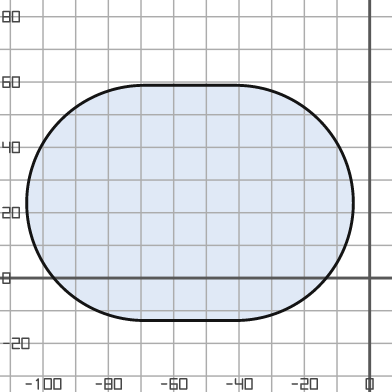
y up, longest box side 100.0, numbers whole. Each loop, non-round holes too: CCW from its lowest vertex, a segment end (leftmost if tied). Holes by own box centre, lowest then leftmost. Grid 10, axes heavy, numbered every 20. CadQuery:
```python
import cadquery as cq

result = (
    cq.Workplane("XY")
    .moveTo(-69.0, -13.0)
    .lineTo(-41.0, -13.0)
    .threePointArc((-5.0, 23.0), (-41.0, 59.0))
    .lineTo(-69.0, 59.0)
    .threePointArc((-105.0, 23.0), (-69.0, -13.0))
    .close()
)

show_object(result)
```